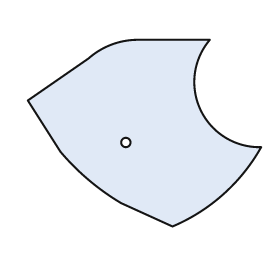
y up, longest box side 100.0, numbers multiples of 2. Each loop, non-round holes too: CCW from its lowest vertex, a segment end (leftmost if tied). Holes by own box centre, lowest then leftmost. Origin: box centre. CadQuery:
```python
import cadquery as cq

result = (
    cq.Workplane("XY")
    .moveTo(12.0, -40.0)
    .threePointArc((34.0, -26.0), (50.0, -6.0))
    .threePointArc((24.0, 10.0), (28.0, 40.0))
    .lineTo(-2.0, 40.0)
    .threePointArc((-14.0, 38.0), (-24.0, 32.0))
    .lineTo(-50.0, 14.0)
    .lineTo(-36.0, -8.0)
    .threePointArc((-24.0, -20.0), (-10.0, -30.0))
    .close()
    .moveTo(-8.0, -4.0)
    .circle(2.0)
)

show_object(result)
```